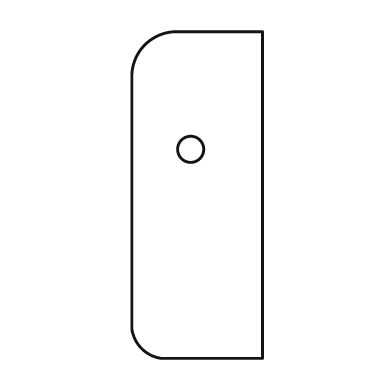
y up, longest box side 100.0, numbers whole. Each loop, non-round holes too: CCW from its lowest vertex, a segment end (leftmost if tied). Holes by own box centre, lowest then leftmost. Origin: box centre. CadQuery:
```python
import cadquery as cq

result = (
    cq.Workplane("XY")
    .moveTo(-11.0, -50.0)
    .lineTo(20.0, -50.0)
    .lineTo(20.0, 50.0)
    .lineTo(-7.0, 50.0)
    .threePointArc((-16.0, 46.0), (-20.0, 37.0))
    .lineTo(-20.0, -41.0)
    .threePointArc((-17.0, -47.0), (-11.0, -50.0))
    .close()
    .moveTo(-2.0, 14.0)
    .circle(4.0)
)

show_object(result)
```